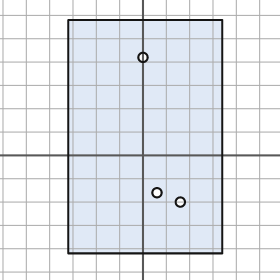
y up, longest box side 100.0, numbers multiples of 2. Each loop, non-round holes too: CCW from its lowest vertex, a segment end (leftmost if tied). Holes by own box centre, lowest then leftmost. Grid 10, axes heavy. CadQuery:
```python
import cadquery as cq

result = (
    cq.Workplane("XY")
    .moveTo(-32.0, -42.0)
    .lineTo(34.0, -42.0)
    .lineTo(34.0, 58.0)
    .lineTo(-32.0, 58.0)
    .close()
    .moveTo(16.0, -20.0)
    .circle(2.0)
    .moveTo(6.0, -16.0)
    .circle(2.0)
    .moveTo(0.0, 42.0)
    .circle(2.0)
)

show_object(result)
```